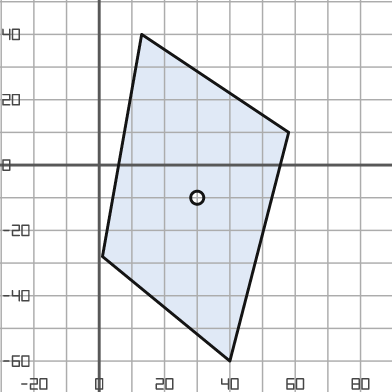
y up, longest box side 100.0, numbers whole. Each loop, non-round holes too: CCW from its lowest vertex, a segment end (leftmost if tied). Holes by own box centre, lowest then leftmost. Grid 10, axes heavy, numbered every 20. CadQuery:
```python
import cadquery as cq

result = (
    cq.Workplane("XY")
    .moveTo(40.0, -60.0)
    .lineTo(58.0, 10.0)
    .lineTo(13.0, 40.0)
    .lineTo(1.0, -28.0)
    .close()
    .moveTo(30.0, -10.0)
    .circle(2.0)
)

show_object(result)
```